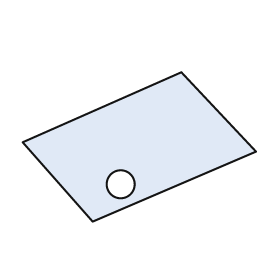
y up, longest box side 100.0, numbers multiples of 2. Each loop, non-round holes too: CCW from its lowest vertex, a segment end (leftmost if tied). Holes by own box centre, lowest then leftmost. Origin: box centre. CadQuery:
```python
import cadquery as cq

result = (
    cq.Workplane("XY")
    .moveTo(-20.0, -32.0)
    .lineTo(50.0, -2.0)
    .lineTo(18.0, 32.0)
    .lineTo(-50.0, 2.0)
    .close()
    .moveTo(-8.0, -16.0)
    .circle(6.0)
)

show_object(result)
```